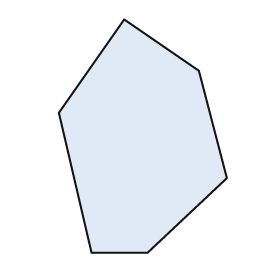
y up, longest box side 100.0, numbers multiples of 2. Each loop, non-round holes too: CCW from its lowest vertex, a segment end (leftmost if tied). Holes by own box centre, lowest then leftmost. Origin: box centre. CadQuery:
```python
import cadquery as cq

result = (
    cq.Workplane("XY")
    .moveTo(-22.0, -50.0)
    .lineTo(2.0, -50.0)
    .lineTo(36.0, -18.0)
    .lineTo(24.0, 28.0)
    .lineTo(-8.0, 50.0)
    .lineTo(-36.0, 10.0)
    .close()
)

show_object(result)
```